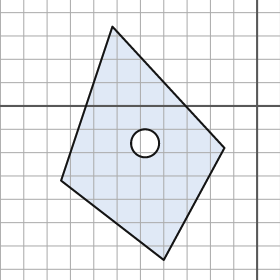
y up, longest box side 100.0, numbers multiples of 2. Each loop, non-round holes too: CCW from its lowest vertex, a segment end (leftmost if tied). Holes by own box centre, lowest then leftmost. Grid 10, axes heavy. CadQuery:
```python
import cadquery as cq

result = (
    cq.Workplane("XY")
    .moveTo(-40.0, -66.0)
    .lineTo(-14.0, -18.0)
    .lineTo(-62.0, 34.0)
    .lineTo(-84.0, -32.0)
    .close()
    .moveTo(-48.0, -16.0)
    .circle(6.0)
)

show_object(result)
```